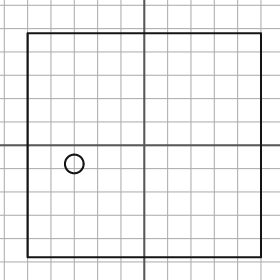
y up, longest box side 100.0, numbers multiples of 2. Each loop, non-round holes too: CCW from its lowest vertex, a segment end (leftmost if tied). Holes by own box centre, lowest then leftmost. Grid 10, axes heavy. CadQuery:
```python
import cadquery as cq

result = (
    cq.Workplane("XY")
    .moveTo(-50.0, -48.0)
    .lineTo(50.0, -48.0)
    .lineTo(50.0, 48.0)
    .lineTo(-50.0, 48.0)
    .close()
    .moveTo(-30.0, -8.0)
    .circle(4.0)
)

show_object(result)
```